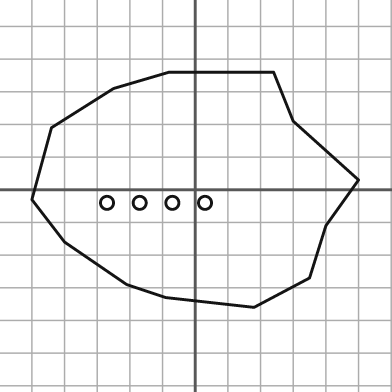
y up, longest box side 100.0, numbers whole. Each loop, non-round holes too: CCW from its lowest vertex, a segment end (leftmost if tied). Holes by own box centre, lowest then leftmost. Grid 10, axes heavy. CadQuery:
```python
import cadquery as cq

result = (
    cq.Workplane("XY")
    .moveTo(18.0, -36.0)
    .lineTo(35.0, -27.0)
    .lineTo(40.0, -11.0)
    .lineTo(50.0, 3.0)
    .lineTo(30.0, 21.0)
    .lineTo(24.0, 36.0)
    .lineTo(-8.0, 36.0)
    .lineTo(-25.0, 31.0)
    .lineTo(-44.0, 19.0)
    .lineTo(-50.0, -3.0)
    .lineTo(-40.0, -16.0)
    .lineTo(-21.0, -29.0)
    .lineTo(-9.0, -33.0)
    .close()
    .moveTo(-27.0, -4.0)
    .circle(2.0)
    .moveTo(-17.0, -4.0)
    .circle(2.0)
    .moveTo(-7.0, -4.0)
    .circle(2.0)
    .moveTo(3.0, -4.0)
    .circle(2.0)
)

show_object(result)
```